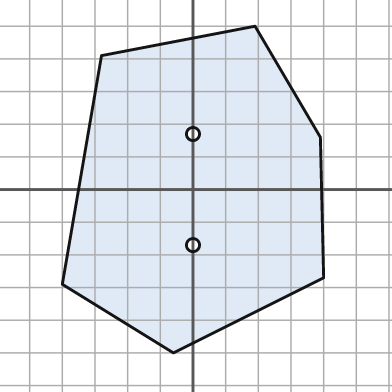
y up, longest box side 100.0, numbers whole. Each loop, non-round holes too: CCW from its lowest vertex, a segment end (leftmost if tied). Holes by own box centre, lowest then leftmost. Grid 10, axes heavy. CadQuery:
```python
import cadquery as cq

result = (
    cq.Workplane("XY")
    .moveTo(-6.0, -50.0)
    .lineTo(40.0, -27.0)
    .lineTo(39.0, 16.0)
    .lineTo(19.0, 50.0)
    .lineTo(-28.0, 41.0)
    .lineTo(-40.0, -29.0)
    .close()
    .moveTo(0.0, -17.0)
    .circle(2.0)
    .moveTo(0.0, 17.0)
    .circle(2.0)
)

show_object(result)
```